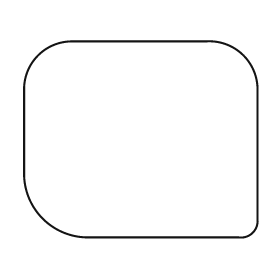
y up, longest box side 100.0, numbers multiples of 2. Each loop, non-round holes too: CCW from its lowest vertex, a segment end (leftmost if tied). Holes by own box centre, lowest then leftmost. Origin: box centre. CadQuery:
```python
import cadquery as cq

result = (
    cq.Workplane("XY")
    .moveTo(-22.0, -42.0)
    .lineTo(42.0, -42.0)
    .threePointArc((48.0, -40.0), (50.0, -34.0))
    .lineTo(50.0, 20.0)
    .threePointArc((44.0, 36.0), (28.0, 42.0))
    .lineTo(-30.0, 42.0)
    .threePointArc((-44.0, 36.0), (-50.0, 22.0))
    .lineTo(-50.0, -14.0)
    .threePointArc((-42.0, -34.0), (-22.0, -42.0))
    .close()
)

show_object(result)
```